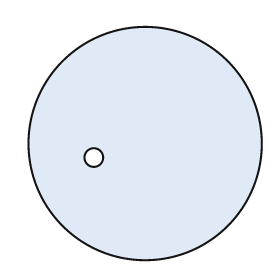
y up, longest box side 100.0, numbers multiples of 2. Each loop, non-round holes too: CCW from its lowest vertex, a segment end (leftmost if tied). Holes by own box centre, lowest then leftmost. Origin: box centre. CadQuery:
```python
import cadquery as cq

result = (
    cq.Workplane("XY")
    .moveTo(0.0, 0.0)
    .circle(50.0)
    .moveTo(-22.0, -6.0)
    .circle(4.0)
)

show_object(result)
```